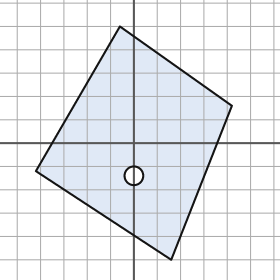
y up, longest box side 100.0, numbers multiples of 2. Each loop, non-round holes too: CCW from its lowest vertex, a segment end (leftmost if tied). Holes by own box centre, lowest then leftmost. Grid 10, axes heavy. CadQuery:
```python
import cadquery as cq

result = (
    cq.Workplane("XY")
    .moveTo(16.0, -50.0)
    .lineTo(42.0, 16.0)
    .lineTo(-6.0, 50.0)
    .lineTo(-42.0, -12.0)
    .close()
    .moveTo(0.0, -14.0)
    .circle(4.0)
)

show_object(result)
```